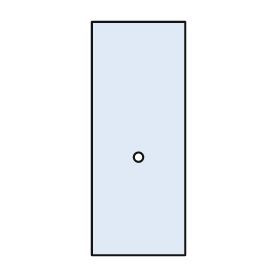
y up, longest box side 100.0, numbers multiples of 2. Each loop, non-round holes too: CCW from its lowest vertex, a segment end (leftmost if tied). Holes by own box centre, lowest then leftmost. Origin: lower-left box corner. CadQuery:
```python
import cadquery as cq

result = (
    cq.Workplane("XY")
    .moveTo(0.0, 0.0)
    .lineTo(40.0, 0.0)
    .lineTo(40.0, 100.0)
    .lineTo(0.0, 100.0)
    .close()
    .moveTo(20.0, 42.0)
    .circle(2.0)
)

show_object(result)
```